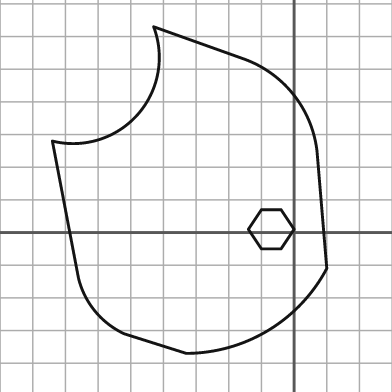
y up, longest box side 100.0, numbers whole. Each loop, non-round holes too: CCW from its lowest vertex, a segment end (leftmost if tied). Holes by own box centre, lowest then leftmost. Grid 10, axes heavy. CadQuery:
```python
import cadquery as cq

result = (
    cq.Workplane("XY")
    .moveTo(-33.0, -37.0)
    .threePointArc((-8.0, -30.0), (10.0, -11.0))
    .lineTo(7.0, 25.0)
    .threePointArc((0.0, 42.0), (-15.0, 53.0))
    .lineTo(-43.0, 63.0)
    .threePointArc((-48.0, 36.0), (-74.0, 28.0))
    .lineTo(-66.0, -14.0)
    .threePointArc((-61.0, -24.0), (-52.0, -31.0))
    .close()
    .moveTo(-10.0, -5.0)
    .lineTo(-4.0, -5.0)
    .lineTo(0.0, 1.0)
    .lineTo(-4.0, 7.0)
    .lineTo(-10.0, 7.0)
    .lineTo(-14.0, 1.0)
    .close()
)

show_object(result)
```